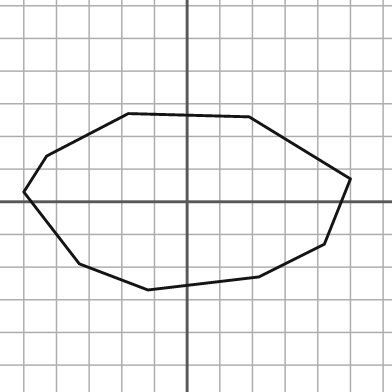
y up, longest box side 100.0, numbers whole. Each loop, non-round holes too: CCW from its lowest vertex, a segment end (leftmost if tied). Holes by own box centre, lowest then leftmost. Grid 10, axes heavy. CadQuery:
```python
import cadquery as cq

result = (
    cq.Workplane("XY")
    .moveTo(-12.0, -27.0)
    .lineTo(22.0, -23.0)
    .lineTo(42.0, -13.0)
    .lineTo(50.0, 7.0)
    .lineTo(19.0, 26.0)
    .lineTo(-18.0, 27.0)
    .lineTo(-43.0, 14.0)
    .lineTo(-50.0, 3.0)
    .lineTo(-33.0, -19.0)
    .close()
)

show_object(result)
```